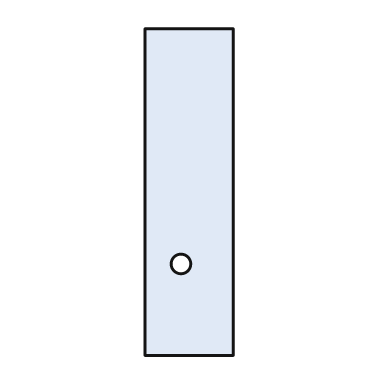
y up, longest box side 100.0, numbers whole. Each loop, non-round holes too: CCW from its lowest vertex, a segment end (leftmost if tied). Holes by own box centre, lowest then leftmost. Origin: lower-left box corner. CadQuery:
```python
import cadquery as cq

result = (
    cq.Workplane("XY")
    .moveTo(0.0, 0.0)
    .lineTo(27.0, 0.0)
    .lineTo(27.0, 100.0)
    .lineTo(0.0, 100.0)
    .close()
    .moveTo(11.0, 28.0)
    .circle(3.0)
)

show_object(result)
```